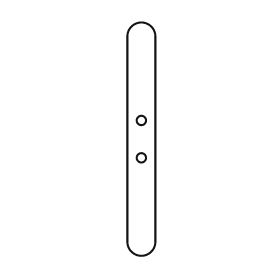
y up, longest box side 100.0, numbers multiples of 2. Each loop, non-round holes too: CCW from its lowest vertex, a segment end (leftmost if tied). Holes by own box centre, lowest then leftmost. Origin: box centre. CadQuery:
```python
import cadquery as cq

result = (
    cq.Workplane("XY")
    .moveTo(-6.0, -44.0)
    .threePointArc((0.0, -50.0), (6.0, -44.0))
    .lineTo(6.0, 44.0)
    .threePointArc((0.0, 50.0), (-6.0, 44.0))
    .close()
    .moveTo(0.0, -8.0)
    .circle(2.0)
    .moveTo(0.0, 8.0)
    .circle(2.0)
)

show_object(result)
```